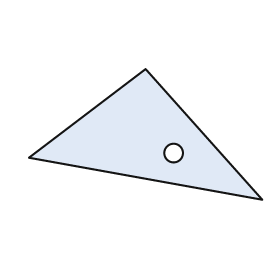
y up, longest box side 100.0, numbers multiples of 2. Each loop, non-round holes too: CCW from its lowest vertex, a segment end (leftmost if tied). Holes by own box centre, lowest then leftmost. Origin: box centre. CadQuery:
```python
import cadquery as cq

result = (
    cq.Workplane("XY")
    .moveTo(50.0, -28.0)
    .lineTo(0.0, 28.0)
    .lineTo(-50.0, -10.0)
    .close()
    .moveTo(12.0, -8.0)
    .circle(4.0)
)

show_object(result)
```